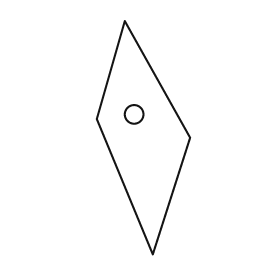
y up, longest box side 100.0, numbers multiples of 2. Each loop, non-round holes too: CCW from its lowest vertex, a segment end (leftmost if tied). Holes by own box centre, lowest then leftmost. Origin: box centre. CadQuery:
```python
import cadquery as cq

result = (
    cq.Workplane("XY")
    .moveTo(4.0, -50.0)
    .lineTo(20.0, 0.0)
    .lineTo(-8.0, 50.0)
    .lineTo(-20.0, 8.0)
    .close()
    .moveTo(-4.0, 10.0)
    .circle(4.0)
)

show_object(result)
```